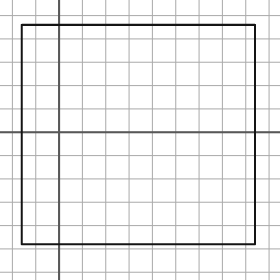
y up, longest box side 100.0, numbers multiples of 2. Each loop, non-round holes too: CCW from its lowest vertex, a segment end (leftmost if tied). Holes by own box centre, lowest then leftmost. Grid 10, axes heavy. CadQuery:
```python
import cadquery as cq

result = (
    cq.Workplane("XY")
    .moveTo(-16.0, -48.0)
    .lineTo(84.0, -48.0)
    .lineTo(84.0, 46.0)
    .lineTo(-16.0, 46.0)
    .close()
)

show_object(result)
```